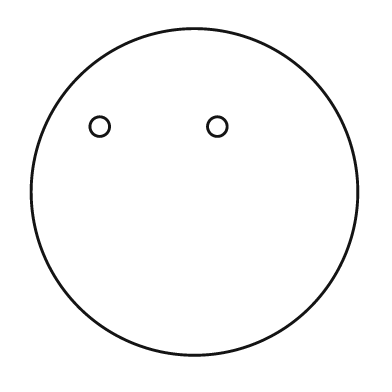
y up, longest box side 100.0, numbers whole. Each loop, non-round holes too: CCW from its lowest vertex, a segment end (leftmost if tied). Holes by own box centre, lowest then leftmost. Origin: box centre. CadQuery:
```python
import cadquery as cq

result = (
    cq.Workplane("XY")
    .moveTo(0.0, 0.0)
    .circle(50.0)
    .moveTo(-29.0, 20.0)
    .circle(3.0)
    .moveTo(7.0, 20.0)
    .circle(3.0)
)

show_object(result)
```